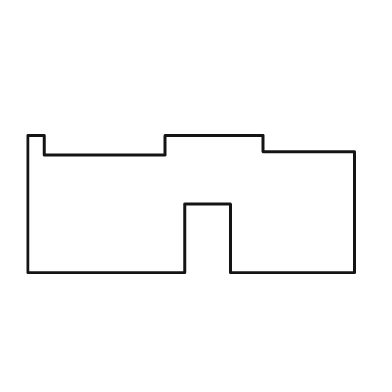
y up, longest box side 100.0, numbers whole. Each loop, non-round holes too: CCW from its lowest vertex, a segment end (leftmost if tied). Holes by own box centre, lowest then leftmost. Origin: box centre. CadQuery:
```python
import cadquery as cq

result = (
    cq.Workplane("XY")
    .moveTo(-50.0, -21.0)
    .lineTo(-2.0, -21.0)
    .lineTo(-2.0, 0.0)
    .lineTo(12.0, 0.0)
    .lineTo(12.0, -21.0)
    .lineTo(50.0, -21.0)
    .lineTo(50.0, 16.0)
    .lineTo(22.0, 16.0)
    .lineTo(22.0, 21.0)
    .lineTo(-8.0, 21.0)
    .lineTo(-8.0, 15.0)
    .lineTo(-45.0, 15.0)
    .lineTo(-45.0, 21.0)
    .lineTo(-50.0, 21.0)
    .close()
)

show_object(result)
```